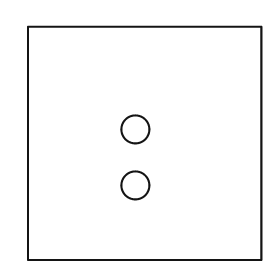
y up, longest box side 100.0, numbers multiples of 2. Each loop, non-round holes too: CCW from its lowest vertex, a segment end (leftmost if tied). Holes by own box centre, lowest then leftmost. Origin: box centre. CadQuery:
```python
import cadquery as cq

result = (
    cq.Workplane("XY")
    .moveTo(-50.0, -50.0)
    .lineTo(50.0, -50.0)
    .lineTo(50.0, 50.0)
    .lineTo(-50.0, 50.0)
    .close()
    .moveTo(-4.0, -18.0)
    .circle(6.0)
    .moveTo(-4.0, 6.0)
    .circle(6.0)
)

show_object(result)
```